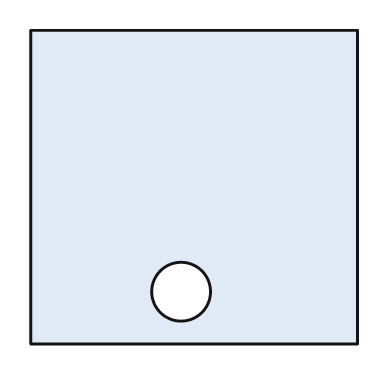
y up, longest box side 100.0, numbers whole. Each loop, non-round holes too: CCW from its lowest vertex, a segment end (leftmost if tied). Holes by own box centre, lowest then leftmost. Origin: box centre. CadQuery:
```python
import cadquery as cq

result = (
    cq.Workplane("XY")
    .moveTo(-50.0, -48.0)
    .lineTo(50.0, -48.0)
    .lineTo(50.0, 48.0)
    .lineTo(-50.0, 48.0)
    .close()
    .moveTo(-4.0, -32.0)
    .circle(9.0)
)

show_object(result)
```